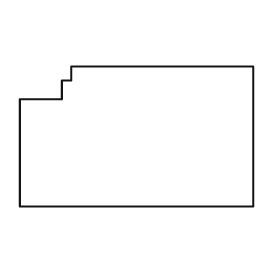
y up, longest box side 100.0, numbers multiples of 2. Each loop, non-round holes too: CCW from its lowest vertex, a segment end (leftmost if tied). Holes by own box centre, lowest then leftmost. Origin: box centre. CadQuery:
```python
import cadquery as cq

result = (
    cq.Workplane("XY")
    .moveTo(-50.0, -30.0)
    .lineTo(50.0, -30.0)
    .lineTo(50.0, 30.0)
    .lineTo(-28.0, 30.0)
    .lineTo(-28.0, 24.0)
    .lineTo(-32.0, 24.0)
    .lineTo(-32.0, 16.0)
    .lineTo(-50.0, 16.0)
    .close()
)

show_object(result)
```